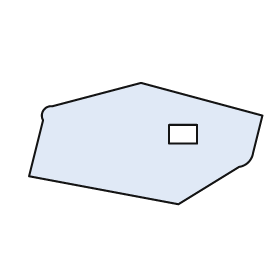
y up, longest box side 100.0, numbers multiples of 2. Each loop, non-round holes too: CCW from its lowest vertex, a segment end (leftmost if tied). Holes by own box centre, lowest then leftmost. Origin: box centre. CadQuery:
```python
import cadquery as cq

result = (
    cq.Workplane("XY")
    .moveTo(14.0, -26.0)
    .lineTo(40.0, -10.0)
    .threePointArc((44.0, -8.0), (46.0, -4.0))
    .lineTo(50.0, 12.0)
    .lineTo(-2.0, 26.0)
    .lineTo(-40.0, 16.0)
    .threePointArc((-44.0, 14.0), (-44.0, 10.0))
    .lineTo(-50.0, -14.0)
    .close()
    .moveTo(10.0, 0.0)
    .lineTo(22.0, 0.0)
    .lineTo(22.0, 8.0)
    .lineTo(10.0, 8.0)
    .close()
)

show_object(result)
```